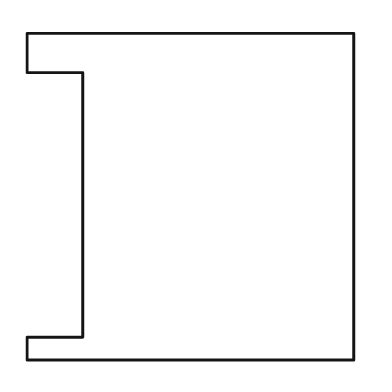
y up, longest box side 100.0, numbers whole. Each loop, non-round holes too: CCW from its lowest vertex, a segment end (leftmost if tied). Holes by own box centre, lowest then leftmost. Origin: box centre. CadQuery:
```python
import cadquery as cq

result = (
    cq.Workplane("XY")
    .moveTo(-50.0, -50.0)
    .lineTo(50.0, -50.0)
    .lineTo(50.0, 50.0)
    .lineTo(-50.0, 50.0)
    .lineTo(-50.0, 38.0)
    .lineTo(-33.0, 38.0)
    .lineTo(-33.0, -43.0)
    .lineTo(-50.0, -43.0)
    .close()
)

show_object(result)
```